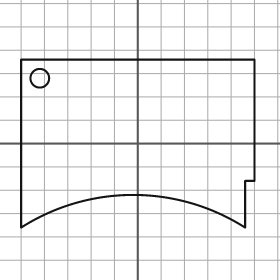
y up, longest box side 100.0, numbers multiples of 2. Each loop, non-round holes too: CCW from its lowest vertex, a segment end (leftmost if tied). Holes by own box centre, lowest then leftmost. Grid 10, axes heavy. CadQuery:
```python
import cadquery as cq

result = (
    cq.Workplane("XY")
    .moveTo(-50.0, -36.0)
    .threePointArc((-2.0, -22.0), (46.0, -36.0))
    .lineTo(46.0, -16.0)
    .lineTo(50.0, -16.0)
    .lineTo(50.0, 36.0)
    .lineTo(-50.0, 36.0)
    .close()
    .moveTo(-42.0, 28.0)
    .circle(4.0)
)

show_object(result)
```